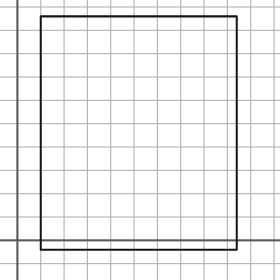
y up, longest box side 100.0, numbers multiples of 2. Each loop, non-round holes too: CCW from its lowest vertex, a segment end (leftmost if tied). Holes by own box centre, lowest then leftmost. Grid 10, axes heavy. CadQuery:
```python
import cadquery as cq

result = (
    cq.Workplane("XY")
    .moveTo(10.0, -4.0)
    .lineTo(94.0, -4.0)
    .lineTo(94.0, 96.0)
    .lineTo(10.0, 96.0)
    .close()
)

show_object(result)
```